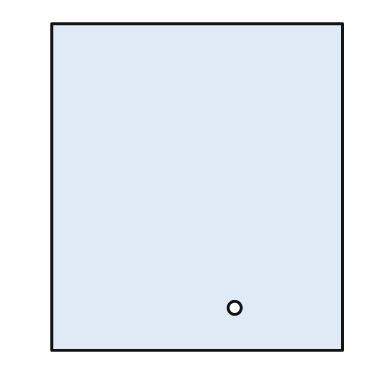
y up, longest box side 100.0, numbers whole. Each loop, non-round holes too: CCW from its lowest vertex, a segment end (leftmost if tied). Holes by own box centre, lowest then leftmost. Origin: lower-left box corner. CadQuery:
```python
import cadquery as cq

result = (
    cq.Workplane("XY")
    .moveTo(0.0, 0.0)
    .lineTo(89.0, 0.0)
    .lineTo(89.0, 100.0)
    .lineTo(0.0, 100.0)
    .close()
    .moveTo(56.0, 13.0)
    .circle(2.0)
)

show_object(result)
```